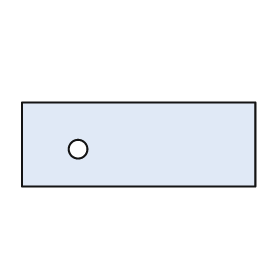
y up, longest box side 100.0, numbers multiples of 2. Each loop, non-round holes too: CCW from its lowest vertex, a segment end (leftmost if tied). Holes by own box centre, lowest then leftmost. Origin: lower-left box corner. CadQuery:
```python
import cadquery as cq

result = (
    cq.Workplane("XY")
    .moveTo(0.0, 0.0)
    .lineTo(100.0, 0.0)
    .lineTo(100.0, 36.0)
    .lineTo(0.0, 36.0)
    .close()
    .moveTo(24.0, 16.0)
    .circle(4.0)
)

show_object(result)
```